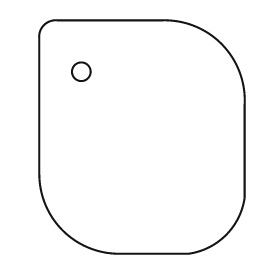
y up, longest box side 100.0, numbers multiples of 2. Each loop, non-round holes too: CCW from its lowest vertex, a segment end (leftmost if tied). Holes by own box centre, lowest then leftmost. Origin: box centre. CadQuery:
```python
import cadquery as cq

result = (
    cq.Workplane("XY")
    .moveTo(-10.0, -50.0)
    .lineTo(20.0, -50.0)
    .threePointArc((36.0, -42.0), (44.0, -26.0))
    .lineTo(44.0, 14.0)
    .threePointArc((34.0, 40.0), (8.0, 50.0))
    .lineTo(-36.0, 50.0)
    .threePointArc((-42.0, 48.0), (-44.0, 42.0))
    .lineTo(-44.0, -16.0)
    .threePointArc((-34.0, -40.0), (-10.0, -50.0))
    .close()
    .moveTo(-26.0, 28.0)
    .circle(4.0)
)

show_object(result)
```